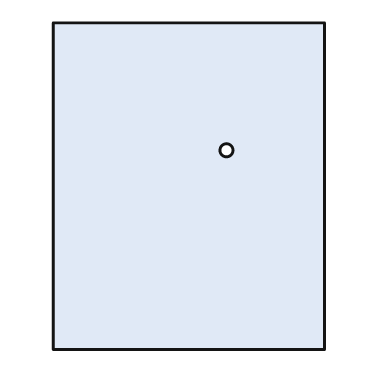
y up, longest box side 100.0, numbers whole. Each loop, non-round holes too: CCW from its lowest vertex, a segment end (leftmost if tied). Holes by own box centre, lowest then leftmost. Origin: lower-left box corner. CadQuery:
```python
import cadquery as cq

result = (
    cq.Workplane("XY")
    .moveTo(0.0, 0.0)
    .lineTo(83.0, 0.0)
    .lineTo(83.0, 100.0)
    .lineTo(0.0, 100.0)
    .close()
    .moveTo(53.0, 61.0)
    .circle(2.0)
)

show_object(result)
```